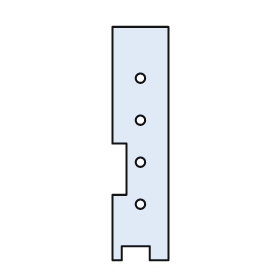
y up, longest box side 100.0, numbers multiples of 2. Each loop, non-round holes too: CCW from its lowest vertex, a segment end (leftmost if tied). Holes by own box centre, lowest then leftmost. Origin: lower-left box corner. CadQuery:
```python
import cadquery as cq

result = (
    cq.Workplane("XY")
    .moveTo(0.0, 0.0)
    .lineTo(4.0, 0.0)
    .lineTo(4.0, 6.0)
    .lineTo(16.0, 6.0)
    .lineTo(16.0, 0.0)
    .lineTo(24.0, 0.0)
    .lineTo(24.0, 100.0)
    .lineTo(0.0, 100.0)
    .lineTo(0.0, 50.0)
    .lineTo(6.0, 50.0)
    .lineTo(6.0, 28.0)
    .lineTo(0.0, 28.0)
    .close()
    .moveTo(12.0, 24.0)
    .circle(2.0)
    .moveTo(12.0, 42.0)
    .circle(2.0)
    .moveTo(12.0, 60.0)
    .circle(2.0)
    .moveTo(12.0, 78.0)
    .circle(2.0)
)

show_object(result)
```